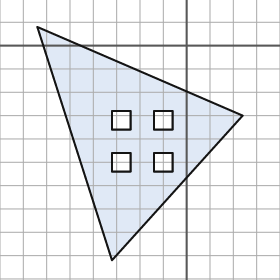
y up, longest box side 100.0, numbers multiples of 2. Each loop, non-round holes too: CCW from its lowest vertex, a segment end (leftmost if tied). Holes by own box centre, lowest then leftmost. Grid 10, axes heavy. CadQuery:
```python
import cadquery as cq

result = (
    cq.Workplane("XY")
    .moveTo(-32.0, -92.0)
    .lineTo(24.0, -30.0)
    .lineTo(-64.0, 8.0)
    .close()
    .moveTo(-32.0, -54.0)
    .lineTo(-24.0, -54.0)
    .lineTo(-24.0, -46.0)
    .lineTo(-32.0, -46.0)
    .close()
    .moveTo(-14.0, -54.0)
    .lineTo(-6.0, -54.0)
    .lineTo(-6.0, -46.0)
    .lineTo(-14.0, -46.0)
    .close()
    .moveTo(-32.0, -36.0)
    .lineTo(-24.0, -36.0)
    .lineTo(-24.0, -28.0)
    .lineTo(-32.0, -28.0)
    .close()
    .moveTo(-14.0, -36.0)
    .lineTo(-6.0, -36.0)
    .lineTo(-6.0, -28.0)
    .lineTo(-14.0, -28.0)
    .close()
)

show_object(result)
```